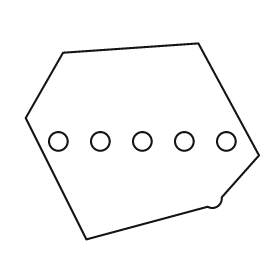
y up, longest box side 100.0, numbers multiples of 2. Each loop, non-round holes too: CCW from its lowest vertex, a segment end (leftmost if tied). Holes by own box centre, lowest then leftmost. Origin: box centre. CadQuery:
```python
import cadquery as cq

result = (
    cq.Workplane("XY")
    .moveTo(-24.0, -42.0)
    .lineTo(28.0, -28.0)
    .threePointArc((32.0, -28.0), (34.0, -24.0))
    .lineTo(50.0, -6.0)
    .lineTo(24.0, 42.0)
    .lineTo(-34.0, 38.0)
    .lineTo(-50.0, 10.0)
    .close()
    .moveTo(-36.0, 0.0)
    .circle(4.0)
    .moveTo(-18.0, 0.0)
    .circle(4.0)
    .moveTo(0.0, 0.0)
    .circle(4.0)
    .moveTo(18.0, 0.0)
    .circle(4.0)
    .moveTo(36.0, 0.0)
    .circle(4.0)
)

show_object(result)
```